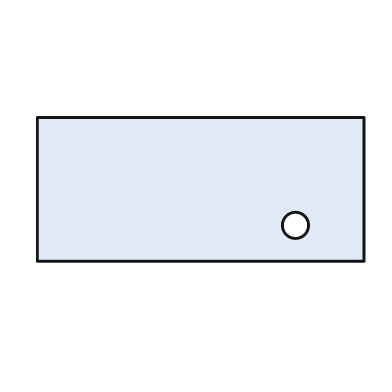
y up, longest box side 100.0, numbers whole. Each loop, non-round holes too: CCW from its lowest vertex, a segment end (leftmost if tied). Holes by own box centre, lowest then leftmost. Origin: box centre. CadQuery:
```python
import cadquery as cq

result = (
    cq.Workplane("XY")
    .moveTo(-50.0, -22.0)
    .lineTo(50.0, -22.0)
    .lineTo(50.0, 22.0)
    .lineTo(-50.0, 22.0)
    .close()
    .moveTo(29.0, -11.0)
    .circle(4.0)
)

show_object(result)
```